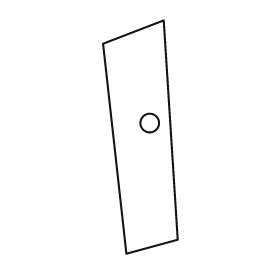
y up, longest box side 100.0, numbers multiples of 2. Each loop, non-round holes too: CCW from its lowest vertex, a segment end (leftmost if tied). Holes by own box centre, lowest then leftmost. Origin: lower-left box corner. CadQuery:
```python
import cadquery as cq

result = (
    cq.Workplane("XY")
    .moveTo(10.0, 0.0)
    .lineTo(32.0, 6.0)
    .lineTo(26.0, 100.0)
    .lineTo(0.0, 90.0)
    .close()
    .moveTo(20.0, 56.0)
    .circle(4.0)
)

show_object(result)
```